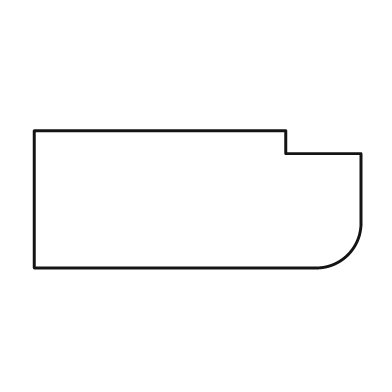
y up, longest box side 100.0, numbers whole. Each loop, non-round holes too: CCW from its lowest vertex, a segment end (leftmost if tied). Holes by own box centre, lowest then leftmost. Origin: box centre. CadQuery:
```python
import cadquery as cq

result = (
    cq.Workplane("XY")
    .moveTo(-50.0, -21.0)
    .lineTo(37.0, -21.0)
    .threePointArc((46.0, -17.0), (50.0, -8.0))
    .lineTo(50.0, 14.0)
    .lineTo(27.0, 14.0)
    .lineTo(27.0, 21.0)
    .lineTo(-50.0, 21.0)
    .close()
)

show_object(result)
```